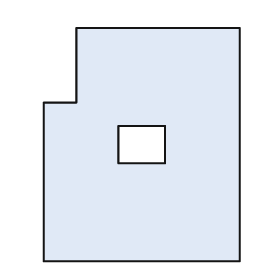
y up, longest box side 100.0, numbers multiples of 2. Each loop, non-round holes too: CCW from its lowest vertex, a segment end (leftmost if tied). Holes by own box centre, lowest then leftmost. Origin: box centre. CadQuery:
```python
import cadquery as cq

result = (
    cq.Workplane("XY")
    .moveTo(-42.0, -50.0)
    .lineTo(42.0, -50.0)
    .lineTo(42.0, 50.0)
    .lineTo(-28.0, 50.0)
    .lineTo(-28.0, 18.0)
    .lineTo(-42.0, 18.0)
    .close()
    .moveTo(-10.0, -8.0)
    .lineTo(10.0, -8.0)
    .lineTo(10.0, 8.0)
    .lineTo(-10.0, 8.0)
    .close()
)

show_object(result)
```